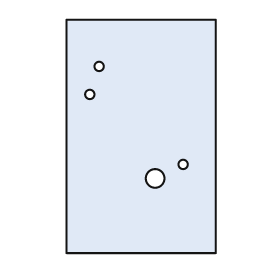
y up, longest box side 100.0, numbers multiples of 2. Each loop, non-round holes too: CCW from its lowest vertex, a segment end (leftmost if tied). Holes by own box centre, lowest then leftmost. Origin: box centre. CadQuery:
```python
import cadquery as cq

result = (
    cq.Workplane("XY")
    .moveTo(-32.0, -50.0)
    .lineTo(32.0, -50.0)
    .lineTo(32.0, 50.0)
    .lineTo(-32.0, 50.0)
    .close()
    .moveTo(6.0, -18.0)
    .circle(4.0)
    .moveTo(18.0, -12.0)
    .circle(2.0)
    .moveTo(-22.0, 18.0)
    .circle(2.0)
    .moveTo(-18.0, 30.0)
    .circle(2.0)
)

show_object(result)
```